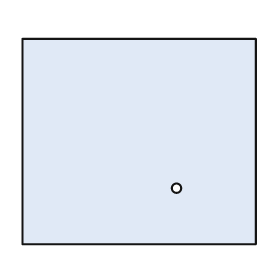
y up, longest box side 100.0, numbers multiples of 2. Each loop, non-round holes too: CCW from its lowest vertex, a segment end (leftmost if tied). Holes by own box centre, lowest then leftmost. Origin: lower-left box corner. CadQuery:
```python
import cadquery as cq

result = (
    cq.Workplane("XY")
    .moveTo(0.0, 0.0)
    .lineTo(100.0, 0.0)
    .lineTo(100.0, 88.0)
    .lineTo(0.0, 88.0)
    .close()
    .moveTo(66.0, 24.0)
    .circle(2.0)
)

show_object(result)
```